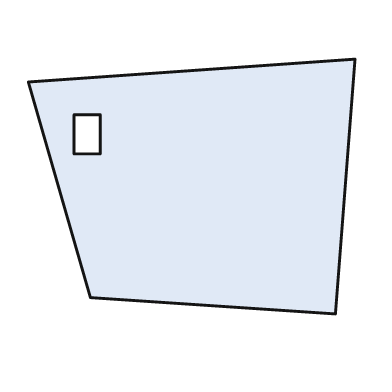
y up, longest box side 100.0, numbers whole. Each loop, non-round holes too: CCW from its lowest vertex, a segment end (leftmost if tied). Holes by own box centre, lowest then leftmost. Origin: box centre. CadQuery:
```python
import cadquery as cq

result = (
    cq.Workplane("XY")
    .moveTo(44.0, -39.0)
    .lineTo(50.0, 39.0)
    .lineTo(-50.0, 32.0)
    .lineTo(-31.0, -34.0)
    .close()
    .moveTo(-36.0, 10.0)
    .lineTo(-28.0, 10.0)
    .lineTo(-28.0, 22.0)
    .lineTo(-36.0, 22.0)
    .close()
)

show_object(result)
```